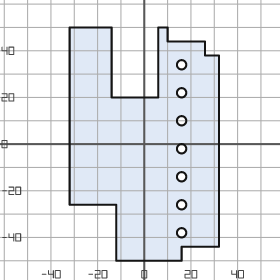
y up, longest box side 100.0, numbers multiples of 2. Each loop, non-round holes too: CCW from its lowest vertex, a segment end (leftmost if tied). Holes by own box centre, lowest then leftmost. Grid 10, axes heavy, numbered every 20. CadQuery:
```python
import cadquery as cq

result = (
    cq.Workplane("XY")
    .moveTo(-12.0, -50.0)
    .lineTo(16.0, -50.0)
    .lineTo(16.0, -44.0)
    .lineTo(32.0, -44.0)
    .lineTo(32.0, 38.0)
    .lineTo(26.0, 38.0)
    .lineTo(26.0, 44.0)
    .lineTo(10.0, 44.0)
    .lineTo(10.0, 50.0)
    .lineTo(6.0, 50.0)
    .lineTo(6.0, 20.0)
    .lineTo(-14.0, 20.0)
    .lineTo(-14.0, 50.0)
    .lineTo(-32.0, 50.0)
    .lineTo(-32.0, -26.0)
    .lineTo(-12.0, -26.0)
    .close()
    .moveTo(16.0, -38.0)
    .circle(2.0)
    .moveTo(16.0, -26.0)
    .circle(2.0)
    .moveTo(16.0, -14.0)
    .circle(2.0)
    .moveTo(16.0, -2.0)
    .circle(2.0)
    .moveTo(16.0, 10.0)
    .circle(2.0)
    .moveTo(16.0, 22.0)
    .circle(2.0)
    .moveTo(16.0, 34.0)
    .circle(2.0)
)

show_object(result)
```